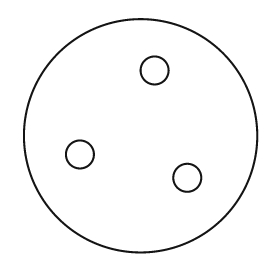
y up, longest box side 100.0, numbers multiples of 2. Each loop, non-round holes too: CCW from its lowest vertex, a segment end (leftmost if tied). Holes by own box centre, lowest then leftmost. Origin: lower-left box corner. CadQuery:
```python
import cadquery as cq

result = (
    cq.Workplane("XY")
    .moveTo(50.0, 50.0)
    .circle(50.0)
    .moveTo(70.0, 32.0)
    .circle(6.0)
    .moveTo(24.0, 42.0)
    .circle(6.0)
    .moveTo(56.0, 78.0)
    .circle(6.0)
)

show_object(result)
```